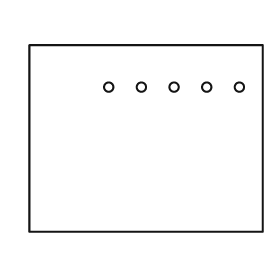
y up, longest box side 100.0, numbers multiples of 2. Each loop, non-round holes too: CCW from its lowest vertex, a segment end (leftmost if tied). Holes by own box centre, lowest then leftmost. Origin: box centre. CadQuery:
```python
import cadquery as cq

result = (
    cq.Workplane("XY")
    .moveTo(-50.0, -40.0)
    .lineTo(50.0, -40.0)
    .lineTo(50.0, 40.0)
    .lineTo(-50.0, 40.0)
    .close()
    .moveTo(-16.0, 22.0)
    .circle(2.0)
    .moveTo(-2.0, 22.0)
    .circle(2.0)
    .moveTo(12.0, 22.0)
    .circle(2.0)
    .moveTo(26.0, 22.0)
    .circle(2.0)
    .moveTo(40.0, 22.0)
    .circle(2.0)
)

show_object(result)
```